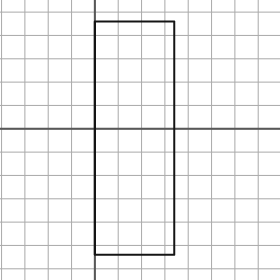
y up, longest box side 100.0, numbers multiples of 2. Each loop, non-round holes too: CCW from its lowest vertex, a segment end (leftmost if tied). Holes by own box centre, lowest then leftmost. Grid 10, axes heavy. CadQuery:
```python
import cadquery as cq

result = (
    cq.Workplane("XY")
    .moveTo(0.0, -54.0)
    .lineTo(34.0, -54.0)
    .lineTo(34.0, 46.0)
    .lineTo(0.0, 46.0)
    .close()
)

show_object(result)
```